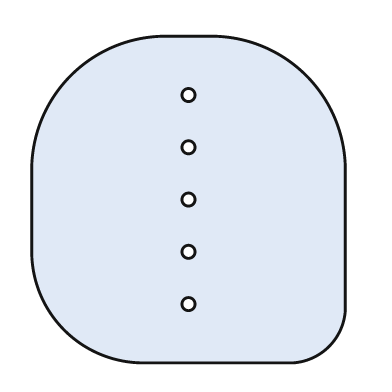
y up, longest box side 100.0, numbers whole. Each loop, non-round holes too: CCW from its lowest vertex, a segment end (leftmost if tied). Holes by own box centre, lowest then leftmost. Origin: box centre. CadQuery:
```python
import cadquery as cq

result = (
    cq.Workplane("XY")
    .moveTo(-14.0, -50.0)
    .lineTo(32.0, -50.0)
    .threePointArc((43.0, -45.0), (48.0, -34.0))
    .lineTo(48.0, 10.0)
    .threePointArc((36.0, 38.0), (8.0, 50.0))
    .lineTo(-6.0, 50.0)
    .threePointArc((-36.0, 38.0), (-48.0, 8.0))
    .lineTo(-48.0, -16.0)
    .threePointArc((-38.0, -40.0), (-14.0, -50.0))
    .close()
    .moveTo(0.0, -32.0)
    .circle(2.0)
    .moveTo(0.0, -16.0)
    .circle(2.0)
    .moveTo(0.0, 0.0)
    .circle(2.0)
    .moveTo(0.0, 16.0)
    .circle(2.0)
    .moveTo(0.0, 32.0)
    .circle(2.0)
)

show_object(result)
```